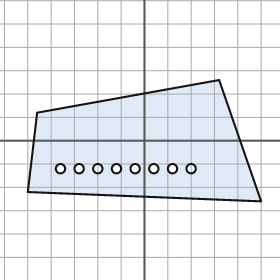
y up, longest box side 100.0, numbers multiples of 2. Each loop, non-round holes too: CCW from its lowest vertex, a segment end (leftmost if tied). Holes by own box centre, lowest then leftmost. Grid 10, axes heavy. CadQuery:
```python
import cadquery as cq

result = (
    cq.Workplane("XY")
    .moveTo(50.0, -26.0)
    .lineTo(32.0, 26.0)
    .lineTo(-46.0, 12.0)
    .lineTo(-50.0, -22.0)
    .close()
    .moveTo(-36.0, -12.0)
    .circle(2.0)
    .moveTo(-28.0, -12.0)
    .circle(2.0)
    .moveTo(-20.0, -12.0)
    .circle(2.0)
    .moveTo(-12.0, -12.0)
    .circle(2.0)
    .moveTo(-4.0, -12.0)
    .circle(2.0)
    .moveTo(4.0, -12.0)
    .circle(2.0)
    .moveTo(12.0, -12.0)
    .circle(2.0)
    .moveTo(20.0, -12.0)
    .circle(2.0)
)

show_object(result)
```